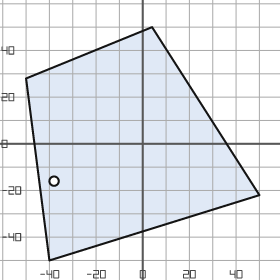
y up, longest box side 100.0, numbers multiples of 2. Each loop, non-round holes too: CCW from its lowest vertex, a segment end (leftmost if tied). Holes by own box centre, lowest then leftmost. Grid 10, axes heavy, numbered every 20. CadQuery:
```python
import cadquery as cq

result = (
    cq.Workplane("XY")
    .moveTo(-40.0, -50.0)
    .lineTo(50.0, -22.0)
    .lineTo(4.0, 50.0)
    .lineTo(-50.0, 28.0)
    .close()
    .moveTo(-38.0, -16.0)
    .circle(2.0)
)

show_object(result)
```